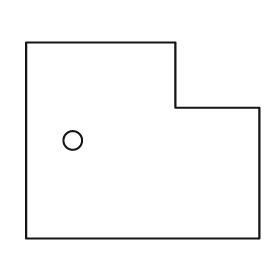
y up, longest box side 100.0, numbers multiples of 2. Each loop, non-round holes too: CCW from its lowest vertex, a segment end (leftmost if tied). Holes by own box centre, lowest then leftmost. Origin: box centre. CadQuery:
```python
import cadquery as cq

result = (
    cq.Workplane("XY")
    .moveTo(-50.0, -42.0)
    .lineTo(50.0, -42.0)
    .lineTo(50.0, 14.0)
    .lineTo(14.0, 14.0)
    .lineTo(14.0, 42.0)
    .lineTo(-50.0, 42.0)
    .close()
    .moveTo(-30.0, 0.0)
    .circle(4.0)
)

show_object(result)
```